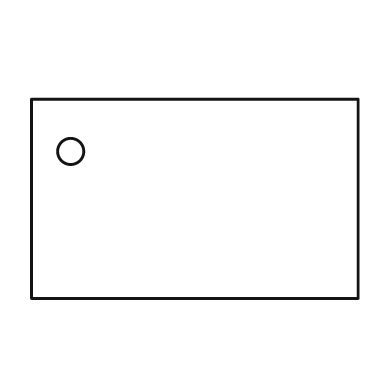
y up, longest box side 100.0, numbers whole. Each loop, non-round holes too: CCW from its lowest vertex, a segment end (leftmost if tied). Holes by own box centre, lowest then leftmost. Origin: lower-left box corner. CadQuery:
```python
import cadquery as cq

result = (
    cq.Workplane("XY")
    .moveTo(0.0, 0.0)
    .lineTo(100.0, 0.0)
    .lineTo(100.0, 61.0)
    .lineTo(0.0, 61.0)
    .close()
    .moveTo(12.0, 45.0)
    .circle(4.0)
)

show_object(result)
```